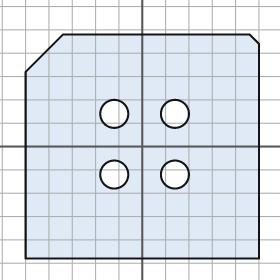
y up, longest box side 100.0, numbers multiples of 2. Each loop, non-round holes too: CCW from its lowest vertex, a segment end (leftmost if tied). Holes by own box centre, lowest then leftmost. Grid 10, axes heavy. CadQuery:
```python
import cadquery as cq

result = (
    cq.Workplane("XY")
    .moveTo(-50.0, -48.0)
    .lineTo(50.0, -48.0)
    .lineTo(50.0, 44.0)
    .lineTo(46.0, 48.0)
    .lineTo(-34.0, 48.0)
    .lineTo(-50.0, 32.0)
    .close()
    .moveTo(-12.0, -12.0)
    .circle(6.0)
    .moveTo(14.0, -12.0)
    .circle(6.0)
    .moveTo(-12.0, 14.0)
    .circle(6.0)
    .moveTo(14.0, 14.0)
    .circle(6.0)
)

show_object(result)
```